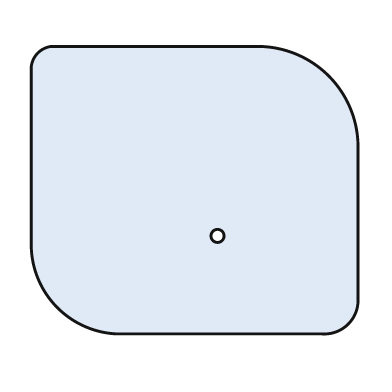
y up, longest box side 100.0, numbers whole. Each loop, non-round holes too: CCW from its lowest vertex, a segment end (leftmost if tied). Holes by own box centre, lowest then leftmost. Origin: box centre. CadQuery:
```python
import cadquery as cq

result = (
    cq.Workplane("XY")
    .moveTo(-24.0, -44.0)
    .lineTo(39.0, -44.0)
    .threePointArc((47.0, -41.0), (50.0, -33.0))
    .lineTo(50.0, 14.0)
    .threePointArc((41.0, 35.0), (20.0, 44.0))
    .lineTo(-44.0, 44.0)
    .threePointArc((-48.0, 42.0), (-50.0, 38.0))
    .lineTo(-50.0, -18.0)
    .threePointArc((-42.0, -36.0), (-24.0, -44.0))
    .close()
    .moveTo(7.0, -14.0)
    .circle(2.0)
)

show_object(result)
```